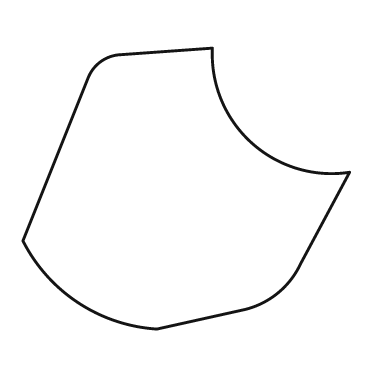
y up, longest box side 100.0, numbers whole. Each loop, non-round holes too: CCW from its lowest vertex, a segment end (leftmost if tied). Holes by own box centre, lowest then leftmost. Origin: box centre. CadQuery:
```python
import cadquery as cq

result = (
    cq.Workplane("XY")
    .moveTo(-9.0, -43.0)
    .lineTo(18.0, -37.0)
    .threePointArc((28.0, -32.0), (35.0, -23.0))
    .lineTo(50.0, 5.0)
    .threePointArc((20.0, 14.0), (8.0, 43.0))
    .lineTo(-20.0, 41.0)
    .threePointArc((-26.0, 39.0), (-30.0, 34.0))
    .lineTo(-50.0, -16.0)
    .threePointArc((-33.0, -35.0), (-9.0, -43.0))
    .close()
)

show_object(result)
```